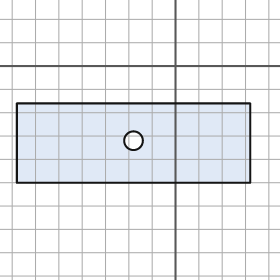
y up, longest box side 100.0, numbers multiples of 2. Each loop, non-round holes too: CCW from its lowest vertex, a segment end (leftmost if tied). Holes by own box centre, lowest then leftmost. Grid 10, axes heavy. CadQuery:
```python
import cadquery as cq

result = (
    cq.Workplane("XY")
    .moveTo(-68.0, -50.0)
    .lineTo(32.0, -50.0)
    .lineTo(32.0, -16.0)
    .lineTo(-68.0, -16.0)
    .close()
    .moveTo(-18.0, -32.0)
    .circle(4.0)
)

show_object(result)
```